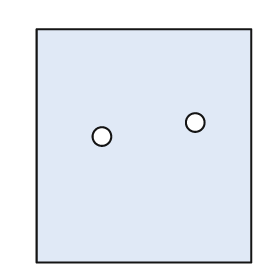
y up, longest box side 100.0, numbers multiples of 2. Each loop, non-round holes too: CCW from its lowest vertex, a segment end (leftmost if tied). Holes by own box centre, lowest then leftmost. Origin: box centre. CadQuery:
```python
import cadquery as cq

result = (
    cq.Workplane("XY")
    .moveTo(-46.0, -50.0)
    .lineTo(46.0, -50.0)
    .lineTo(46.0, 50.0)
    .lineTo(-46.0, 50.0)
    .close()
    .moveTo(-18.0, 4.0)
    .circle(4.0)
    .moveTo(22.0, 10.0)
    .circle(4.0)
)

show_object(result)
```